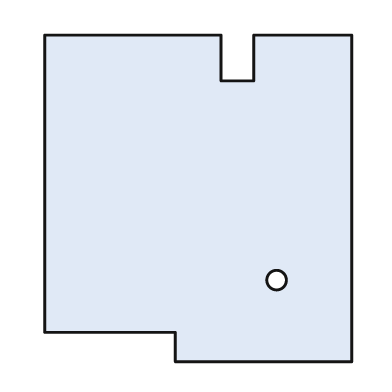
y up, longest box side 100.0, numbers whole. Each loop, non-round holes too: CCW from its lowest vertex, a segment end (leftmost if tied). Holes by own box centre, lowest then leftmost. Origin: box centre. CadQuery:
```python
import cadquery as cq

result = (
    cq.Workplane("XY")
    .moveTo(-7.0, -50.0)
    .lineTo(47.0, -50.0)
    .lineTo(47.0, 50.0)
    .lineTo(17.0, 50.0)
    .lineTo(17.0, 36.0)
    .lineTo(7.0, 36.0)
    .lineTo(7.0, 50.0)
    .lineTo(-47.0, 50.0)
    .lineTo(-47.0, -41.0)
    .lineTo(-7.0, -41.0)
    .close()
    .moveTo(24.0, -25.0)
    .circle(3.0)
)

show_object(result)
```